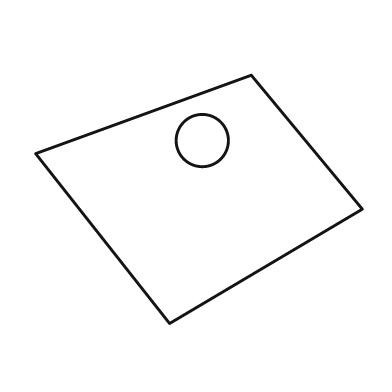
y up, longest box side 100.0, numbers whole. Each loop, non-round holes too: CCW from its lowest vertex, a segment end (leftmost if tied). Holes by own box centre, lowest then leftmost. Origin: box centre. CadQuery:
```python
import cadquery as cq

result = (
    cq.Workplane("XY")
    .moveTo(-9.0, -38.0)
    .lineTo(50.0, -3.0)
    .lineTo(16.0, 38.0)
    .lineTo(-50.0, 14.0)
    .close()
    .moveTo(1.0, 18.0)
    .circle(8.0)
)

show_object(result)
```